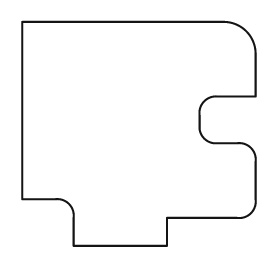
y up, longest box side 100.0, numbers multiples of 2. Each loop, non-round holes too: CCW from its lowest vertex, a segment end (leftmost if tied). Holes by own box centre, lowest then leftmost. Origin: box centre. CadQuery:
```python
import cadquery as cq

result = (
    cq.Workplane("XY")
    .moveTo(-28.0, -48.0)
    .lineTo(12.0, -48.0)
    .lineTo(12.0, -36.0)
    .lineTo(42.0, -36.0)
    .threePointArc((48.0, -34.0), (50.0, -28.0))
    .lineTo(50.0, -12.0)
    .threePointArc((48.0, -6.0), (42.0, -4.0))
    .lineTo(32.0, -4.0)
    .threePointArc((28.0, -2.0), (26.0, 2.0))
    .lineTo(26.0, 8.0)
    .threePointArc((28.0, 14.0), (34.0, 16.0))
    .lineTo(50.0, 16.0)
    .lineTo(50.0, 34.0)
    .threePointArc((46.0, 44.0), (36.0, 48.0))
    .lineTo(-50.0, 48.0)
    .lineTo(-50.0, -28.0)
    .lineTo(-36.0, -28.0)
    .threePointArc((-30.0, -30.0), (-28.0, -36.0))
    .close()
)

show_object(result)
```